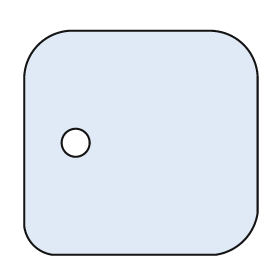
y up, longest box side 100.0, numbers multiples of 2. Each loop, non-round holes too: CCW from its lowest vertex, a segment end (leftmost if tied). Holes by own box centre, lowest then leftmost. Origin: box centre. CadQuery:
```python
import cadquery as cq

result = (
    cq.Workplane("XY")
    .moveTo(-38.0, -48.0)
    .lineTo(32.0, -48.0)
    .threePointArc((44.0, -42.0), (50.0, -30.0))
    .lineTo(50.0, 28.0)
    .threePointArc((44.0, 42.0), (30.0, 48.0))
    .lineTo(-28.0, 48.0)
    .threePointArc((-44.0, 42.0), (-50.0, 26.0))
    .lineTo(-50.0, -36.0)
    .threePointArc((-46.0, -44.0), (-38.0, -48.0))
    .close()
    .moveTo(-28.0, 0.0)
    .circle(6.0)
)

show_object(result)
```